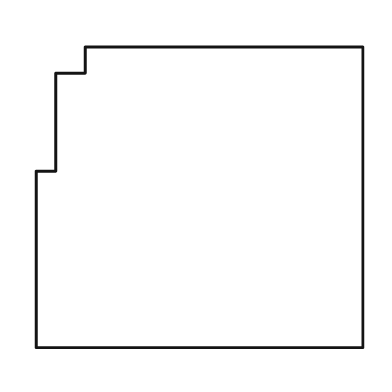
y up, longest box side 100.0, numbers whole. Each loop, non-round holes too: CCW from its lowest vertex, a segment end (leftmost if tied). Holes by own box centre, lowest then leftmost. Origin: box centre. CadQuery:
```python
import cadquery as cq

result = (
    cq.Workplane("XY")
    .moveTo(-50.0, -46.0)
    .lineTo(50.0, -46.0)
    .lineTo(50.0, 46.0)
    .lineTo(-35.0, 46.0)
    .lineTo(-35.0, 38.0)
    .lineTo(-44.0, 38.0)
    .lineTo(-44.0, 8.0)
    .lineTo(-50.0, 8.0)
    .close()
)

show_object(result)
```